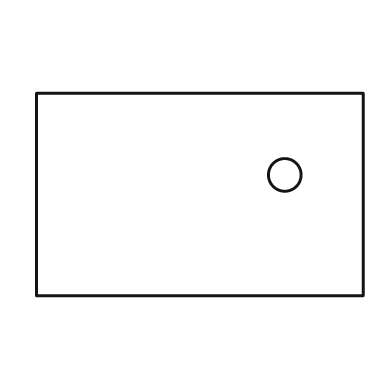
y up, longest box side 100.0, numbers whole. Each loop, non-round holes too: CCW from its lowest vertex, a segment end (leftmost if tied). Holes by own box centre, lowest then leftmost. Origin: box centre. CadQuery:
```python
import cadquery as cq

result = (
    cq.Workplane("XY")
    .moveTo(-50.0, -31.0)
    .lineTo(50.0, -31.0)
    .lineTo(50.0, 31.0)
    .lineTo(-50.0, 31.0)
    .close()
    .moveTo(26.0, 6.0)
    .circle(5.0)
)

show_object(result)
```